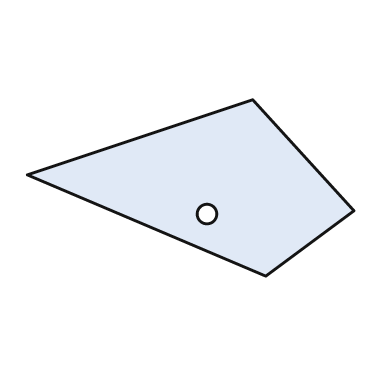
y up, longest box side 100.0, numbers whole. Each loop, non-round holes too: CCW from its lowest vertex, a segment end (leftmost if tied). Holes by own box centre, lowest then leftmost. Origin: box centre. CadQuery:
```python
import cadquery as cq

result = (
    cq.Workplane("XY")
    .moveTo(23.0, -27.0)
    .lineTo(50.0, -7.0)
    .lineTo(19.0, 27.0)
    .lineTo(-50.0, 4.0)
    .close()
    .moveTo(5.0, -8.0)
    .circle(3.0)
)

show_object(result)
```